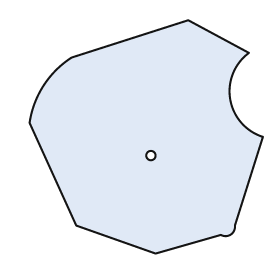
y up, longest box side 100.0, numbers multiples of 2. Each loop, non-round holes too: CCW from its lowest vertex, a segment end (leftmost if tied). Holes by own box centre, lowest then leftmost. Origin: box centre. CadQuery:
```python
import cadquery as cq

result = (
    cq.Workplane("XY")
    .moveTo(4.0, -50.0)
    .lineTo(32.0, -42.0)
    .threePointArc((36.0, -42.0), (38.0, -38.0))
    .lineTo(50.0, 0.0)
    .threePointArc((36.0, 16.0), (44.0, 36.0))
    .lineTo(18.0, 50.0)
    .lineTo(-32.0, 34.0)
    .threePointArc((-44.0, 22.0), (-50.0, 6.0))
    .lineTo(-30.0, -38.0)
    .close()
    .moveTo(2.0, -8.0)
    .circle(2.0)
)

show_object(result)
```